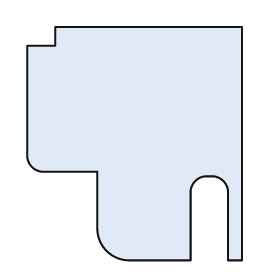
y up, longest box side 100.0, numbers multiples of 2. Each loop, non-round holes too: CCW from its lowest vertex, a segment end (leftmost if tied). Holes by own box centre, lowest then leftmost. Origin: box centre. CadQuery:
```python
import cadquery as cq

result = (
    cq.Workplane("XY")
    .moveTo(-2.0, -50.0)
    .lineTo(24.0, -50.0)
    .lineTo(24.0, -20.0)
    .threePointArc((26.0, -16.0), (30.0, -14.0))
    .lineTo(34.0, -14.0)
    .threePointArc((38.0, -16.0), (40.0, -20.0))
    .lineTo(40.0, -50.0)
    .lineTo(46.0, -50.0)
    .lineTo(46.0, 50.0)
    .lineTo(-34.0, 50.0)
    .lineTo(-34.0, 42.0)
    .lineTo(-46.0, 42.0)
    .lineTo(-46.0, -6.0)
    .threePointArc((-44.0, -10.0), (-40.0, -12.0))
    .lineTo(-16.0, -12.0)
    .lineTo(-16.0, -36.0)
    .threePointArc((-12.0, -46.0), (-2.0, -50.0))
    .close()
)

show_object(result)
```